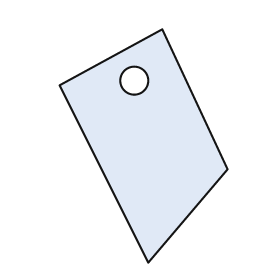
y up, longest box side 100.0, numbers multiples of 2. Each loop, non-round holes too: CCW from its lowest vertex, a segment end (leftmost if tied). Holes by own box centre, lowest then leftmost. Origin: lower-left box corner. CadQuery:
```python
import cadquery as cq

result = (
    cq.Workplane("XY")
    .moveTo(38.0, 0.0)
    .lineTo(72.0, 40.0)
    .lineTo(44.0, 100.0)
    .lineTo(0.0, 76.0)
    .close()
    .moveTo(32.0, 78.0)
    .circle(6.0)
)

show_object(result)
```